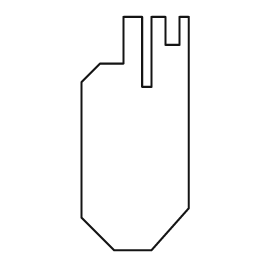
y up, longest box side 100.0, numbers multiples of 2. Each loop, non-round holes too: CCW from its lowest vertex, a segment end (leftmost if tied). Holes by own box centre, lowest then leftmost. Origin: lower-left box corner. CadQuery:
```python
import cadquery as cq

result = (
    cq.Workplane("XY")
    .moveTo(14.0, 0.0)
    .lineTo(30.0, 0.0)
    .lineTo(46.0, 18.0)
    .lineTo(46.0, 100.0)
    .lineTo(42.0, 100.0)
    .lineTo(42.0, 88.0)
    .lineTo(36.0, 88.0)
    .lineTo(36.0, 100.0)
    .lineTo(30.0, 100.0)
    .lineTo(30.0, 70.0)
    .lineTo(26.0, 70.0)
    .lineTo(26.0, 100.0)
    .lineTo(18.0, 100.0)
    .lineTo(18.0, 80.0)
    .lineTo(8.0, 80.0)
    .lineTo(0.0, 72.0)
    .lineTo(0.0, 14.0)
    .close()
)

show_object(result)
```